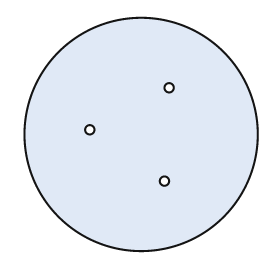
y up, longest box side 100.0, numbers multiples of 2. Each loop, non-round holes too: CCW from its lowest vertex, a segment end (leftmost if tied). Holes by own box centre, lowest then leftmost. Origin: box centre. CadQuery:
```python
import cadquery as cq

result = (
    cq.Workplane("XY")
    .moveTo(0.0, 0.0)
    .circle(50.0)
    .moveTo(10.0, -20.0)
    .circle(2.0)
    .moveTo(-22.0, 2.0)
    .circle(2.0)
    .moveTo(12.0, 20.0)
    .circle(2.0)
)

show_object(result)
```